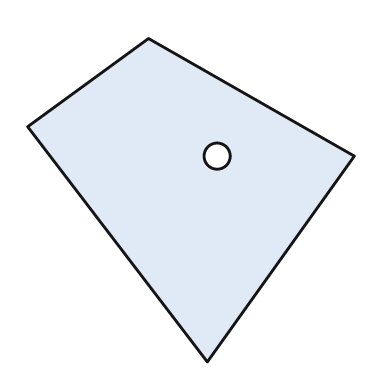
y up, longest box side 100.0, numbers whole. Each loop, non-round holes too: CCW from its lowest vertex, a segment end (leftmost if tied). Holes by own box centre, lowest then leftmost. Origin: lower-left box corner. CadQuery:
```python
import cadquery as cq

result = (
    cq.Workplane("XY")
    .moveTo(55.0, 0.0)
    .lineTo(100.0, 63.0)
    .lineTo(37.0, 99.0)
    .lineTo(0.0, 72.0)
    .close()
    .moveTo(58.0, 63.0)
    .circle(4.0)
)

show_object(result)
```